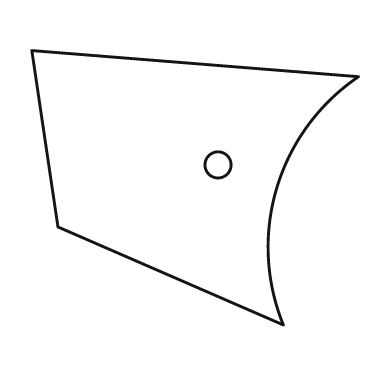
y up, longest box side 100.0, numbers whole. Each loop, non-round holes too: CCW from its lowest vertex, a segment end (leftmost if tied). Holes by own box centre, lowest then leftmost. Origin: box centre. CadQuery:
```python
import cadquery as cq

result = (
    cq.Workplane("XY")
    .moveTo(27.0, -42.0)
    .threePointArc((25.0, 0.0), (50.0, 34.0))
    .lineTo(-50.0, 42.0)
    .lineTo(-42.0, -12.0)
    .close()
    .moveTo(7.0, 7.0)
    .circle(4.0)
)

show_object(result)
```